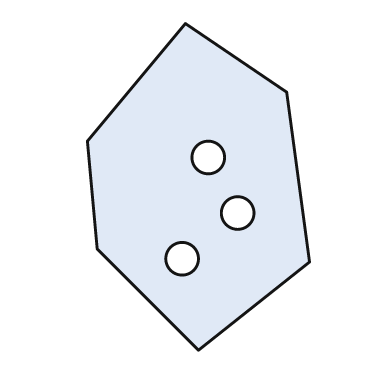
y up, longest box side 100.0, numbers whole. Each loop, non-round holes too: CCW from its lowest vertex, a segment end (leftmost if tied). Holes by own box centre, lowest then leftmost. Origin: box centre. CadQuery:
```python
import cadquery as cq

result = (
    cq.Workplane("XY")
    .moveTo(0.0, -50.0)
    .lineTo(34.0, -23.0)
    .lineTo(27.0, 29.0)
    .lineTo(-4.0, 50.0)
    .lineTo(-34.0, 14.0)
    .lineTo(-31.0, -19.0)
    .close()
    .moveTo(-5.0, -22.0)
    .circle(5.0)
    .moveTo(12.0, -8.0)
    .circle(5.0)
    .moveTo(3.0, 9.0)
    .circle(5.0)
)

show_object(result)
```